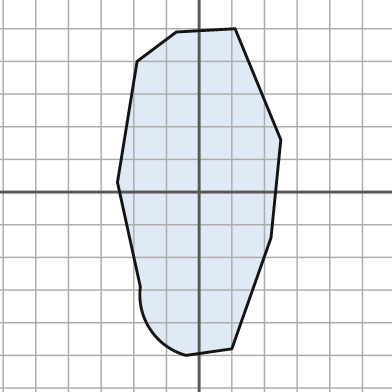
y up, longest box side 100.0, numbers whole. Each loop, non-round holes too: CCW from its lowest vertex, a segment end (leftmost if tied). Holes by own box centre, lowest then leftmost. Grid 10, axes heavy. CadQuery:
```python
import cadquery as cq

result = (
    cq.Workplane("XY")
    .moveTo(-4.0, -50.0)
    .lineTo(10.0, -48.0)
    .lineTo(22.0, -14.0)
    .lineTo(25.0, 16.0)
    .lineTo(11.0, 50.0)
    .lineTo(-7.0, 49.0)
    .lineTo(-19.0, 40.0)
    .lineTo(-25.0, 3.0)
    .lineTo(-18.0, -29.0)
    .threePointArc((-15.0, -42.0), (-4.0, -50.0))
    .close()
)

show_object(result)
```